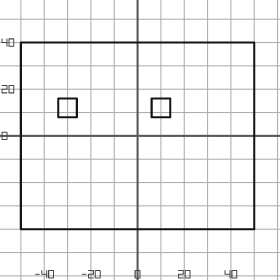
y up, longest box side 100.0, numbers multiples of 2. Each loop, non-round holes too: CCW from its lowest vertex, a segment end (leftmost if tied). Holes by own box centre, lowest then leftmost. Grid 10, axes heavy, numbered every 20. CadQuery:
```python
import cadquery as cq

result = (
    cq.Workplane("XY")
    .moveTo(-50.0, -40.0)
    .lineTo(50.0, -40.0)
    .lineTo(50.0, 40.0)
    .lineTo(-50.0, 40.0)
    .close()
    .moveTo(-34.0, 8.0)
    .lineTo(-26.0, 8.0)
    .lineTo(-26.0, 16.0)
    .lineTo(-34.0, 16.0)
    .close()
    .moveTo(6.0, 8.0)
    .lineTo(14.0, 8.0)
    .lineTo(14.0, 16.0)
    .lineTo(6.0, 16.0)
    .close()
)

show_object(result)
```